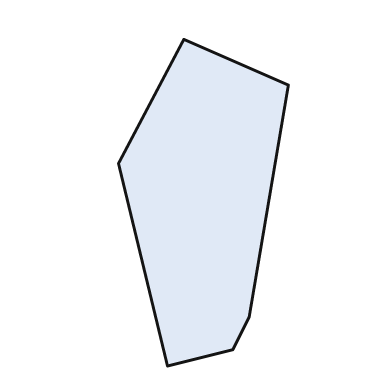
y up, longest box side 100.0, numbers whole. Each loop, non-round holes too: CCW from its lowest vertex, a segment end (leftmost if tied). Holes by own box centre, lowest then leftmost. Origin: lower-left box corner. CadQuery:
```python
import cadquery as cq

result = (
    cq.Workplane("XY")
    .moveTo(15.0, 0.0)
    .lineTo(35.0, 5.0)
    .lineTo(40.0, 15.0)
    .lineTo(52.0, 86.0)
    .lineTo(20.0, 100.0)
    .lineTo(0.0, 62.0)
    .close()
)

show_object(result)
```